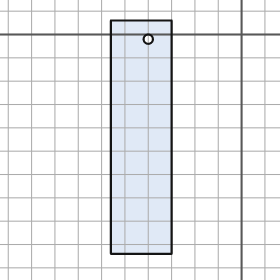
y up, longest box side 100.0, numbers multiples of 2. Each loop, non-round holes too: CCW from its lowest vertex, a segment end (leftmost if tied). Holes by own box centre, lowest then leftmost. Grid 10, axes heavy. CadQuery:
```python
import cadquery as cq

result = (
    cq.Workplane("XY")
    .moveTo(-56.0, -94.0)
    .lineTo(-30.0, -94.0)
    .lineTo(-30.0, 6.0)
    .lineTo(-56.0, 6.0)
    .close()
    .moveTo(-40.0, -2.0)
    .circle(2.0)
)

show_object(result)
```